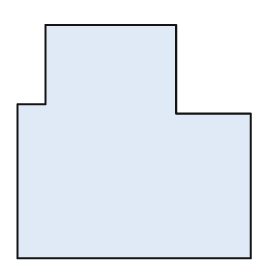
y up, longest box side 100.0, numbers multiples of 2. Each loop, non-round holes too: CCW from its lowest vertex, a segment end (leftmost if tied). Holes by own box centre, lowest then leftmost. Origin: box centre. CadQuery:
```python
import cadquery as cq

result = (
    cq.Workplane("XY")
    .moveTo(-50.0, -50.0)
    .lineTo(50.0, -50.0)
    .lineTo(50.0, 12.0)
    .lineTo(18.0, 12.0)
    .lineTo(18.0, 50.0)
    .lineTo(-38.0, 50.0)
    .lineTo(-38.0, 16.0)
    .lineTo(-50.0, 16.0)
    .close()
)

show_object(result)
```